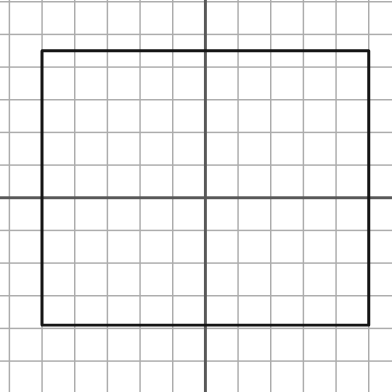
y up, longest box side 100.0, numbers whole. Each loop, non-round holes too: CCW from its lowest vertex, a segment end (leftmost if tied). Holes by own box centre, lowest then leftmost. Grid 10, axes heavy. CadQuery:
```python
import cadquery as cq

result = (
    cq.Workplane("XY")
    .moveTo(-50.0, -39.0)
    .lineTo(50.0, -39.0)
    .lineTo(50.0, 45.0)
    .lineTo(-50.0, 45.0)
    .close()
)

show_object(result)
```